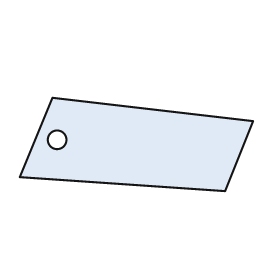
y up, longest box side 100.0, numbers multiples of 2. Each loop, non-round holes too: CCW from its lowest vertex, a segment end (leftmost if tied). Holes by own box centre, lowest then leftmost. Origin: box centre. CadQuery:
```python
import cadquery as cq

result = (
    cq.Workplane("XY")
    .moveTo(38.0, -20.0)
    .lineTo(50.0, 10.0)
    .lineTo(-36.0, 20.0)
    .lineTo(-50.0, -14.0)
    .close()
    .moveTo(-34.0, 2.0)
    .circle(4.0)
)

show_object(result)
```